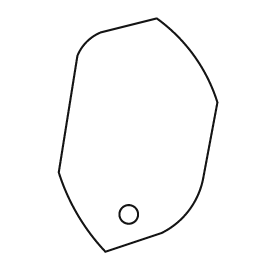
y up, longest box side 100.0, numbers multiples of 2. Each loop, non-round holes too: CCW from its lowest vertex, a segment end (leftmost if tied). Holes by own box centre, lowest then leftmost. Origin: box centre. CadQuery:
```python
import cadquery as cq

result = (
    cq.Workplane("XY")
    .moveTo(-14.0, -50.0)
    .lineTo(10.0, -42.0)
    .threePointArc((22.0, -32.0), (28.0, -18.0))
    .lineTo(34.0, 14.0)
    .threePointArc((24.0, 34.0), (8.0, 50.0))
    .lineTo(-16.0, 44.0)
    .threePointArc((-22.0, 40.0), (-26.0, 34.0))
    .lineTo(-34.0, -16.0)
    .threePointArc((-26.0, -34.0), (-14.0, -50.0))
    .close()
    .moveTo(-4.0, -34.0)
    .circle(4.0)
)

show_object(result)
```